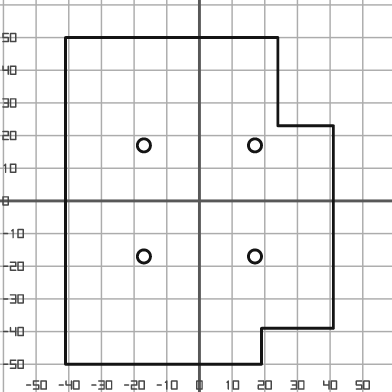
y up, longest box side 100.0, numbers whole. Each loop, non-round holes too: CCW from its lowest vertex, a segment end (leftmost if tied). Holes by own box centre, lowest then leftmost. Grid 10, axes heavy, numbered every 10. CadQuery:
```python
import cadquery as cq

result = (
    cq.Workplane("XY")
    .moveTo(-41.0, -50.0)
    .lineTo(19.0, -50.0)
    .lineTo(19.0, -39.0)
    .lineTo(41.0, -39.0)
    .lineTo(41.0, 23.0)
    .lineTo(24.0, 23.0)
    .lineTo(24.0, 50.0)
    .lineTo(-41.0, 50.0)
    .close()
    .moveTo(-17.0, -17.0)
    .circle(2.0)
    .moveTo(17.0, -17.0)
    .circle(2.0)
    .moveTo(-17.0, 17.0)
    .circle(2.0)
    .moveTo(17.0, 17.0)
    .circle(2.0)
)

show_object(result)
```